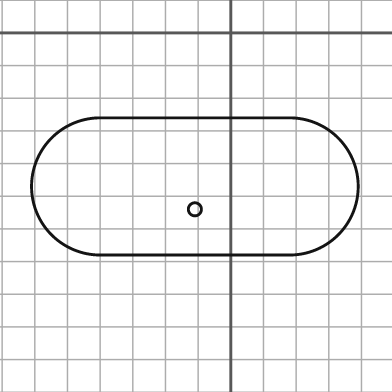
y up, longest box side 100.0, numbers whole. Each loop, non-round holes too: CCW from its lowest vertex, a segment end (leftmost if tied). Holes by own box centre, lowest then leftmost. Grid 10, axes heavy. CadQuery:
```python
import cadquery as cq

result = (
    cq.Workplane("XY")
    .moveTo(-40.0, -68.0)
    .lineTo(18.0, -68.0)
    .threePointArc((39.0, -47.0), (18.0, -26.0))
    .lineTo(-40.0, -26.0)
    .threePointArc((-61.0, -47.0), (-40.0, -68.0))
    .close()
    .moveTo(-11.0, -54.0)
    .circle(2.0)
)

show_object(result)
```